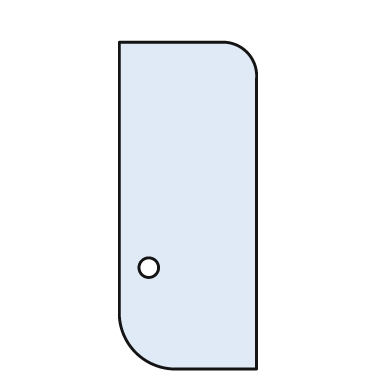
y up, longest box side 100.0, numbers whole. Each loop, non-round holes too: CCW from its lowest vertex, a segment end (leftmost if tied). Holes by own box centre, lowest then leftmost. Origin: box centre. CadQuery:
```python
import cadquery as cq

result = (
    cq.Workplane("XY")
    .moveTo(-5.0, -50.0)
    .lineTo(21.0, -50.0)
    .lineTo(21.0, 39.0)
    .threePointArc((18.0, 47.0), (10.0, 50.0))
    .lineTo(-21.0, 50.0)
    .lineTo(-21.0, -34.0)
    .threePointArc((-16.0, -45.0), (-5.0, -50.0))
    .close()
    .moveTo(-12.0, -19.0)
    .circle(3.0)
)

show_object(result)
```